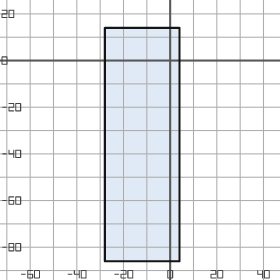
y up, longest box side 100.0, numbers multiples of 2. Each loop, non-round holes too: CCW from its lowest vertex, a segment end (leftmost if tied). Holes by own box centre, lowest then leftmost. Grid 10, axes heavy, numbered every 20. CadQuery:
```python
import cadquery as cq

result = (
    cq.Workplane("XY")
    .moveTo(-28.0, -86.0)
    .lineTo(4.0, -86.0)
    .lineTo(4.0, 14.0)
    .lineTo(-28.0, 14.0)
    .close()
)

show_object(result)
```